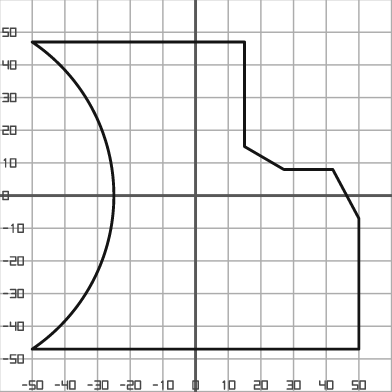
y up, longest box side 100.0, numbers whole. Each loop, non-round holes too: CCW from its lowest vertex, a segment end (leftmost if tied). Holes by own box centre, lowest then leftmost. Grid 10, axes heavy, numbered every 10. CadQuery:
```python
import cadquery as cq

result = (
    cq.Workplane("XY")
    .moveTo(-50.0, -47.0)
    .lineTo(50.0, -47.0)
    .lineTo(50.0, -7.0)
    .lineTo(42.0, 8.0)
    .lineTo(27.0, 8.0)
    .lineTo(15.0, 15.0)
    .lineTo(15.0, 47.0)
    .lineTo(-50.0, 47.0)
    .threePointArc((-25.0, 0.0), (-50.0, -47.0))
    .close()
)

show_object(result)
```